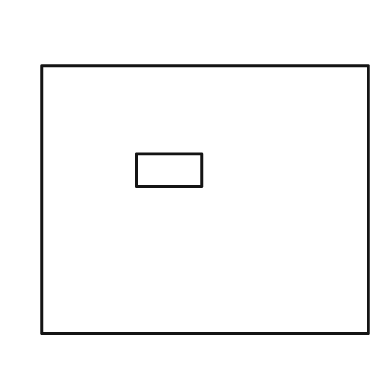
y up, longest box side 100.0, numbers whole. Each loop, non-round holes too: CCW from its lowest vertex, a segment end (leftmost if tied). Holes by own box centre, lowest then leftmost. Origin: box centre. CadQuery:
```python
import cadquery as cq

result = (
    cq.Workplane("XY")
    .moveTo(-50.0, -41.0)
    .lineTo(50.0, -41.0)
    .lineTo(50.0, 41.0)
    .lineTo(-50.0, 41.0)
    .close()
    .moveTo(-21.0, 4.0)
    .lineTo(-1.0, 4.0)
    .lineTo(-1.0, 14.0)
    .lineTo(-21.0, 14.0)
    .close()
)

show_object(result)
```